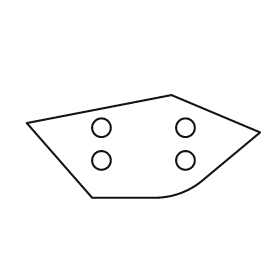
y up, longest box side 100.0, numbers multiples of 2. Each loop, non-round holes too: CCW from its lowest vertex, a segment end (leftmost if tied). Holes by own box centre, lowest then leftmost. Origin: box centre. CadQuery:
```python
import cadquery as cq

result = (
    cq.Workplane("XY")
    .moveTo(-22.0, -22.0)
    .lineTo(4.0, -22.0)
    .threePointArc((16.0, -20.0), (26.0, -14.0))
    .lineTo(50.0, 6.0)
    .lineTo(12.0, 22.0)
    .lineTo(-50.0, 10.0)
    .close()
    .moveTo(-18.0, -6.0)
    .circle(4.0)
    .moveTo(18.0, -6.0)
    .circle(4.0)
    .moveTo(-18.0, 8.0)
    .circle(4.0)
    .moveTo(18.0, 8.0)
    .circle(4.0)
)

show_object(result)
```